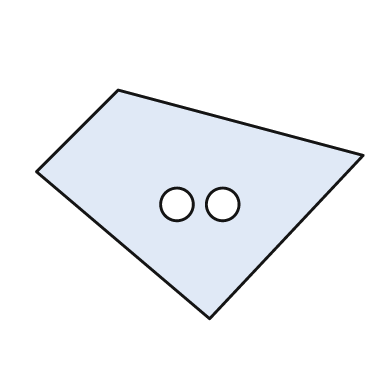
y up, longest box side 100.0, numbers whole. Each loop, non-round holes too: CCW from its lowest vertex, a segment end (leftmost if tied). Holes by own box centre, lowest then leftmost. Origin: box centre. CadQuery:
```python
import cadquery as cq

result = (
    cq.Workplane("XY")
    .moveTo(3.0, -35.0)
    .lineTo(50.0, 15.0)
    .lineTo(-25.0, 35.0)
    .lineTo(-50.0, 10.0)
    .close()
    .moveTo(-7.0, 0.0)
    .circle(5.0)
    .moveTo(7.0, 0.0)
    .circle(5.0)
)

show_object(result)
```